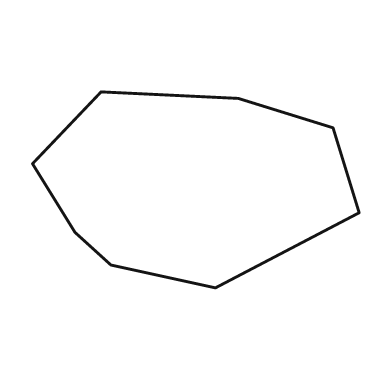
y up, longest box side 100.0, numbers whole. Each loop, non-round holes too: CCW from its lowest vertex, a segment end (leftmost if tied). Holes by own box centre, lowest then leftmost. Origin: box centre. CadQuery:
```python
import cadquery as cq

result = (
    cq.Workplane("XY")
    .moveTo(6.0, -30.0)
    .lineTo(50.0, -7.0)
    .lineTo(42.0, 19.0)
    .lineTo(13.0, 28.0)
    .lineTo(-29.0, 30.0)
    .lineTo(-50.0, 8.0)
    .lineTo(-37.0, -13.0)
    .lineTo(-26.0, -23.0)
    .close()
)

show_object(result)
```